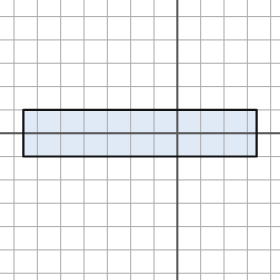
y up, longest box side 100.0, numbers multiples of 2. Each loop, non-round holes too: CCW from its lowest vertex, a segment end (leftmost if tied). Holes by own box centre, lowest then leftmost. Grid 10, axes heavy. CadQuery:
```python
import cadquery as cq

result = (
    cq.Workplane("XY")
    .moveTo(-66.0, -10.0)
    .lineTo(34.0, -10.0)
    .lineTo(34.0, 10.0)
    .lineTo(-66.0, 10.0)
    .close()
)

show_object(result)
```